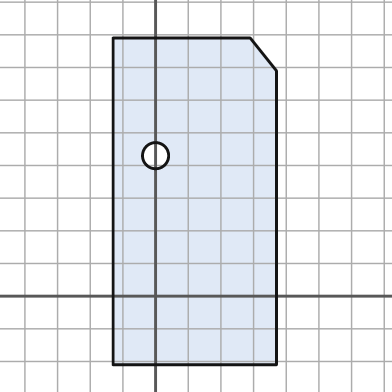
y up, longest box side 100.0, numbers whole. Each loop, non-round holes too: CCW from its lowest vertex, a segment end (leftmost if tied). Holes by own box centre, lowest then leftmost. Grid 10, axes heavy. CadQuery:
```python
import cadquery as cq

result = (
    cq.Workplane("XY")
    .moveTo(-13.0, -21.0)
    .lineTo(37.0, -21.0)
    .lineTo(37.0, 69.0)
    .lineTo(29.0, 79.0)
    .lineTo(-13.0, 79.0)
    .close()
    .moveTo(0.0, 43.0)
    .circle(4.0)
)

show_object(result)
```